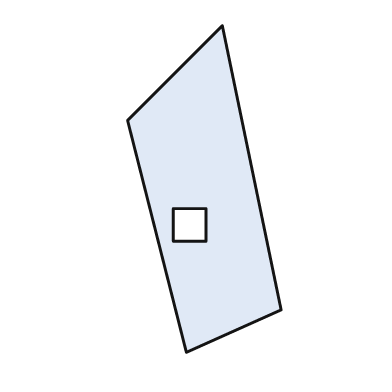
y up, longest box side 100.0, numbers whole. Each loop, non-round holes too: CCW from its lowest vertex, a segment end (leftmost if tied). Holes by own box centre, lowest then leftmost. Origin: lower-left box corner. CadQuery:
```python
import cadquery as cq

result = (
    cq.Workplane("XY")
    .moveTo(18.0, 0.0)
    .lineTo(47.0, 13.0)
    .lineTo(29.0, 100.0)
    .lineTo(0.0, 71.0)
    .close()
    .moveTo(14.0, 34.0)
    .lineTo(24.0, 34.0)
    .lineTo(24.0, 44.0)
    .lineTo(14.0, 44.0)
    .close()
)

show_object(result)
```